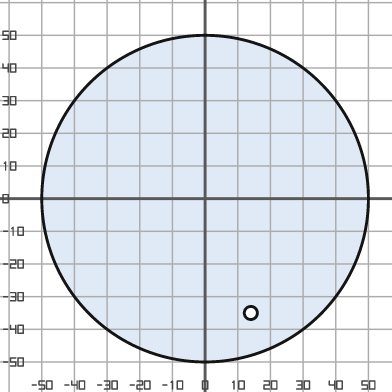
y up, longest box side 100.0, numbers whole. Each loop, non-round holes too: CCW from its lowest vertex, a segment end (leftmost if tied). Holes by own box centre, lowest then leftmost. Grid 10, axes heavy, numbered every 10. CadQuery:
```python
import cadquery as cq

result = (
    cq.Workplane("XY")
    .moveTo(0.0, 0.0)
    .circle(50.0)
    .moveTo(14.0, -35.0)
    .circle(2.0)
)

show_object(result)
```